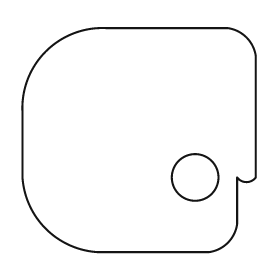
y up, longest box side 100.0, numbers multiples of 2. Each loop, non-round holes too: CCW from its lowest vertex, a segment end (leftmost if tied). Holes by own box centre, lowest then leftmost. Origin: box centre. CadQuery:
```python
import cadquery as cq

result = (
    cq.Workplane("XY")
    .moveTo(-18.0, -48.0)
    .lineTo(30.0, -48.0)
    .threePointArc((38.0, -44.0), (42.0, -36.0))
    .lineTo(42.0, -16.0)
    .threePointArc((46.0, -18.0), (50.0, -16.0))
    .lineTo(50.0, 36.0)
    .threePointArc((46.0, 44.0), (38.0, 48.0))
    .lineTo(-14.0, 48.0)
    .threePointArc((-40.0, 38.0), (-50.0, 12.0))
    .lineTo(-50.0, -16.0)
    .threePointArc((-40.0, -38.0), (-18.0, -48.0))
    .close()
    .moveTo(24.0, -16.0)
    .circle(10.0)
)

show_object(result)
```